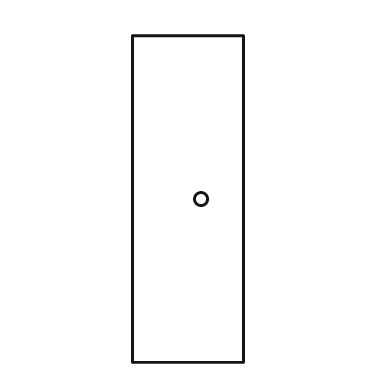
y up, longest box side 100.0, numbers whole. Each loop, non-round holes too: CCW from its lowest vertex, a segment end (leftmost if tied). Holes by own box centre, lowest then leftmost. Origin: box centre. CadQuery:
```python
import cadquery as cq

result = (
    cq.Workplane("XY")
    .moveTo(-17.0, -50.0)
    .lineTo(17.0, -50.0)
    .lineTo(17.0, 50.0)
    .lineTo(-17.0, 50.0)
    .close()
    .moveTo(4.0, 0.0)
    .circle(2.0)
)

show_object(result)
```